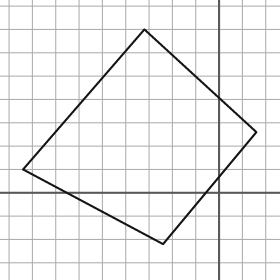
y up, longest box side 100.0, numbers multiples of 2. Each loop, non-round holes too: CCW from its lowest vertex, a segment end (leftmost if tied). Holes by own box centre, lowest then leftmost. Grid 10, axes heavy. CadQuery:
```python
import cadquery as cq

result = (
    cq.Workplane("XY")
    .moveTo(-24.0, -22.0)
    .lineTo(16.0, 26.0)
    .lineTo(-32.0, 70.0)
    .lineTo(-84.0, 10.0)
    .close()
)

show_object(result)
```